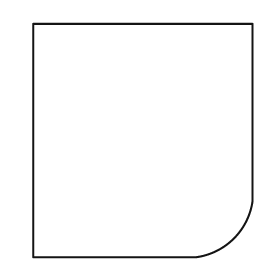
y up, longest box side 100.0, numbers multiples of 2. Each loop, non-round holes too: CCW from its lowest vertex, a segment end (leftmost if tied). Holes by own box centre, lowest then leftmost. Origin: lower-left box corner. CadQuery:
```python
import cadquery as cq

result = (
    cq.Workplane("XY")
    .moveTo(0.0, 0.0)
    .lineTo(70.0, 0.0)
    .threePointArc((86.0, 8.0), (94.0, 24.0))
    .lineTo(94.0, 100.0)
    .lineTo(0.0, 100.0)
    .close()
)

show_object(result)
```